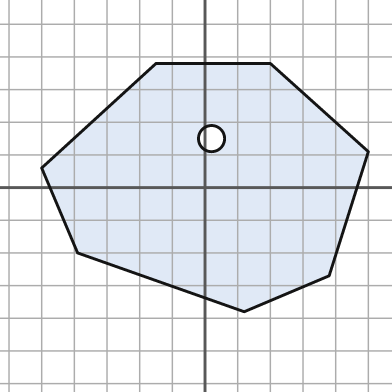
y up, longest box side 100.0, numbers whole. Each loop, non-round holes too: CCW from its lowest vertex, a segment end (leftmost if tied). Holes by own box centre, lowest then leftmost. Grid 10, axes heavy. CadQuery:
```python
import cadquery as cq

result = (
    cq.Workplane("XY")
    .moveTo(12.0, -38.0)
    .lineTo(38.0, -27.0)
    .lineTo(50.0, 11.0)
    .lineTo(20.0, 38.0)
    .lineTo(-15.0, 38.0)
    .lineTo(-50.0, 6.0)
    .lineTo(-39.0, -20.0)
    .close()
    .moveTo(2.0, 15.0)
    .circle(4.0)
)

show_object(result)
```